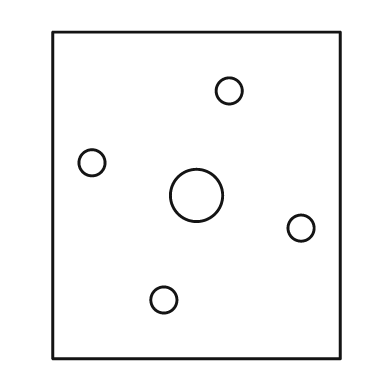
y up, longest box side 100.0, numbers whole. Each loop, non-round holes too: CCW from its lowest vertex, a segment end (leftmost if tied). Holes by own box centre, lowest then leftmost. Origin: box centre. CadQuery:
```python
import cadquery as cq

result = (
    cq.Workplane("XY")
    .moveTo(-44.0, -50.0)
    .lineTo(44.0, -50.0)
    .lineTo(44.0, 50.0)
    .lineTo(-44.0, 50.0)
    .close()
    .moveTo(-10.0, -32.0)
    .circle(4.0)
    .moveTo(32.0, -10.0)
    .circle(4.0)
    .moveTo(0.0, 0.0)
    .circle(8.0)
    .moveTo(-32.0, 10.0)
    .circle(4.0)
    .moveTo(10.0, 32.0)
    .circle(4.0)
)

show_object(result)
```